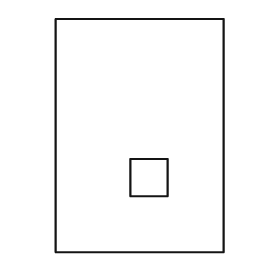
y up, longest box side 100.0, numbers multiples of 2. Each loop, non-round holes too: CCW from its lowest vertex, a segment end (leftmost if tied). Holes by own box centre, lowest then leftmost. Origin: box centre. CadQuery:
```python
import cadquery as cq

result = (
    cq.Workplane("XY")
    .moveTo(-36.0, -50.0)
    .lineTo(36.0, -50.0)
    .lineTo(36.0, 50.0)
    .lineTo(-36.0, 50.0)
    .close()
    .moveTo(-4.0, -26.0)
    .lineTo(12.0, -26.0)
    .lineTo(12.0, -10.0)
    .lineTo(-4.0, -10.0)
    .close()
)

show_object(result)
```